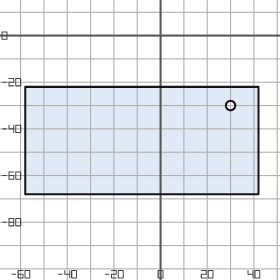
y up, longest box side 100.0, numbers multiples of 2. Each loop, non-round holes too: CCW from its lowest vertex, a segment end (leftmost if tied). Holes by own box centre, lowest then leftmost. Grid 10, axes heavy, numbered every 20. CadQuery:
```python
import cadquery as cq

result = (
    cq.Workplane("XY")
    .moveTo(-58.0, -68.0)
    .lineTo(42.0, -68.0)
    .lineTo(42.0, -22.0)
    .lineTo(-58.0, -22.0)
    .close()
    .moveTo(30.0, -30.0)
    .circle(2.0)
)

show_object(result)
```